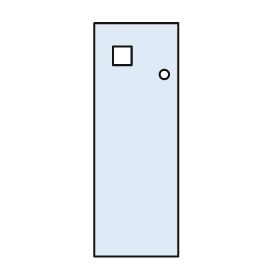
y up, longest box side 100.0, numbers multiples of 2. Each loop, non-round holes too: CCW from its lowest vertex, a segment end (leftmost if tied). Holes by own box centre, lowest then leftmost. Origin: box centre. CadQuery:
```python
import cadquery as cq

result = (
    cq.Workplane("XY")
    .moveTo(-18.0, -50.0)
    .lineTo(18.0, -50.0)
    .lineTo(18.0, 50.0)
    .lineTo(-18.0, 50.0)
    .close()
    .moveTo(12.0, 28.0)
    .circle(2.0)
    .moveTo(-10.0, 32.0)
    .lineTo(-2.0, 32.0)
    .lineTo(-2.0, 40.0)
    .lineTo(-10.0, 40.0)
    .close()
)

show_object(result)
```